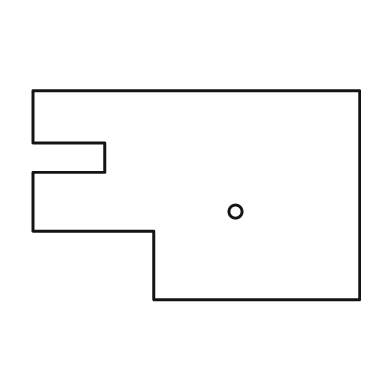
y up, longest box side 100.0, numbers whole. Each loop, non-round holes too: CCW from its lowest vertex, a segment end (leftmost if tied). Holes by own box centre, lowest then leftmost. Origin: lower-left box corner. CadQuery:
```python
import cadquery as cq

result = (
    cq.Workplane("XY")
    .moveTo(37.0, 0.0)
    .lineTo(100.0, 0.0)
    .lineTo(100.0, 64.0)
    .lineTo(0.0, 64.0)
    .lineTo(0.0, 48.0)
    .lineTo(22.0, 48.0)
    .lineTo(22.0, 39.0)
    .lineTo(0.0, 39.0)
    .lineTo(0.0, 21.0)
    .lineTo(37.0, 21.0)
    .close()
    .moveTo(62.0, 27.0)
    .circle(2.0)
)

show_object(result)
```